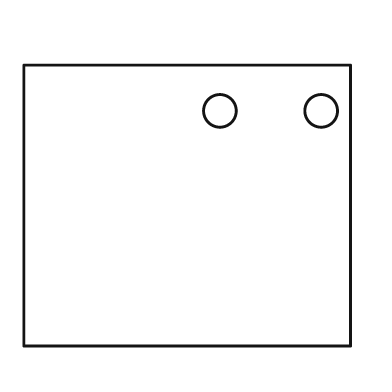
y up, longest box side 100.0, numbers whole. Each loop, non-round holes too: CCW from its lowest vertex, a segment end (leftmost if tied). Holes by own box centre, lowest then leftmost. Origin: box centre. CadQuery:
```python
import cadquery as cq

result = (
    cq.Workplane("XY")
    .moveTo(-50.0, -43.0)
    .lineTo(50.0, -43.0)
    .lineTo(50.0, 43.0)
    .lineTo(-50.0, 43.0)
    .close()
    .moveTo(10.0, 29.0)
    .circle(5.0)
    .moveTo(41.0, 29.0)
    .circle(5.0)
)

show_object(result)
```